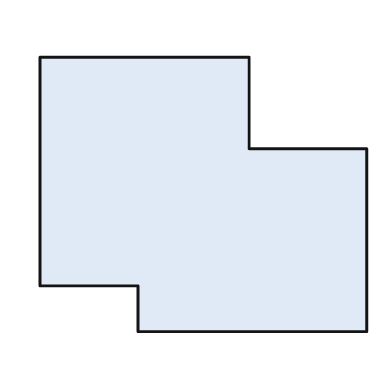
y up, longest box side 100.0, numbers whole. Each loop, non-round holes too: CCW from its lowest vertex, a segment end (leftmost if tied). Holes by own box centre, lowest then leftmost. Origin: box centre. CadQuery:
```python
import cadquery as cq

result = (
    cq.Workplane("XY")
    .moveTo(-20.0, -42.0)
    .lineTo(50.0, -42.0)
    .lineTo(50.0, 14.0)
    .lineTo(14.0, 14.0)
    .lineTo(14.0, 42.0)
    .lineTo(-50.0, 42.0)
    .lineTo(-50.0, -28.0)
    .lineTo(-20.0, -28.0)
    .close()
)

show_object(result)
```